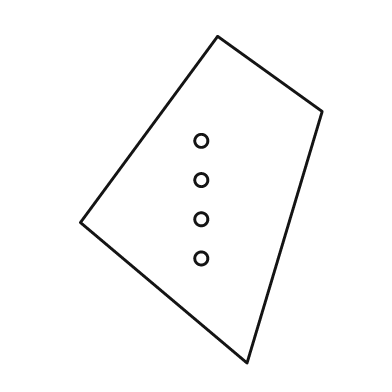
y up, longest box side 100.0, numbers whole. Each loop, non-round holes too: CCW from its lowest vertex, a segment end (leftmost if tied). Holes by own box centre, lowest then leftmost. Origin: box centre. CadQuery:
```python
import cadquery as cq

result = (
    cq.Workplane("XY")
    .moveTo(14.0, -50.0)
    .lineTo(37.0, 27.0)
    .lineTo(5.0, 50.0)
    .lineTo(-37.0, -7.0)
    .close()
    .moveTo(0.0, -18.0)
    .circle(2.0)
    .moveTo(0.0, -6.0)
    .circle(2.0)
    .moveTo(0.0, 6.0)
    .circle(2.0)
    .moveTo(0.0, 18.0)
    .circle(2.0)
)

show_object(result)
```